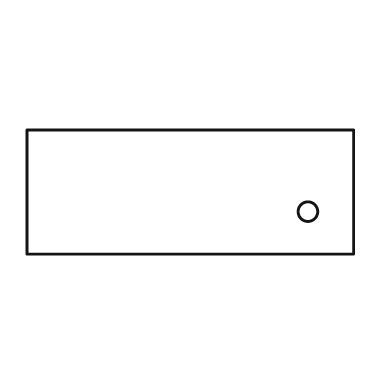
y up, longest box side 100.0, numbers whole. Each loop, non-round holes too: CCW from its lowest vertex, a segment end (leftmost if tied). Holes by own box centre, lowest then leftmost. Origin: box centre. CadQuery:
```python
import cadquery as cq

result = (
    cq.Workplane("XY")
    .moveTo(-50.0, -19.0)
    .lineTo(50.0, -19.0)
    .lineTo(50.0, 19.0)
    .lineTo(-50.0, 19.0)
    .close()
    .moveTo(36.0, -6.0)
    .circle(3.0)
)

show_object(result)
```